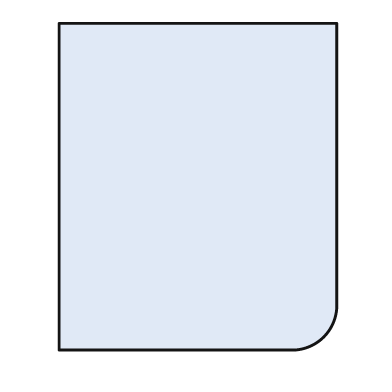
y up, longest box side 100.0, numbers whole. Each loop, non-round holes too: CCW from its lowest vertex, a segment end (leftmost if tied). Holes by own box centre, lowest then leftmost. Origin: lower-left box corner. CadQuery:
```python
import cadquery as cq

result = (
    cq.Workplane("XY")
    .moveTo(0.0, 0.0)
    .lineTo(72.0, 0.0)
    .threePointArc((81.0, 4.0), (85.0, 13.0))
    .lineTo(85.0, 100.0)
    .lineTo(0.0, 100.0)
    .close()
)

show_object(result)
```